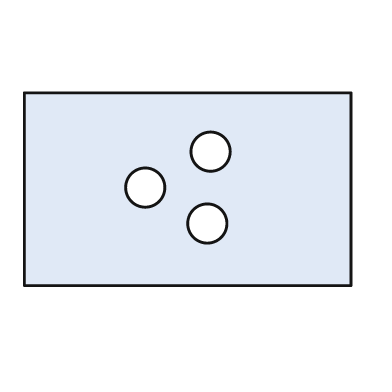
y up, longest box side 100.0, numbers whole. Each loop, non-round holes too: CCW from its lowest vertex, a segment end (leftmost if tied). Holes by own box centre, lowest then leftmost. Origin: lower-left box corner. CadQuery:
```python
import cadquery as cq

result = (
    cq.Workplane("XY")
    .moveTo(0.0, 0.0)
    .lineTo(100.0, 0.0)
    .lineTo(100.0, 59.0)
    .lineTo(0.0, 59.0)
    .close()
    .moveTo(56.0, 19.0)
    .circle(6.0)
    .moveTo(37.0, 30.0)
    .circle(6.0)
    .moveTo(57.0, 41.0)
    .circle(6.0)
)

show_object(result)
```